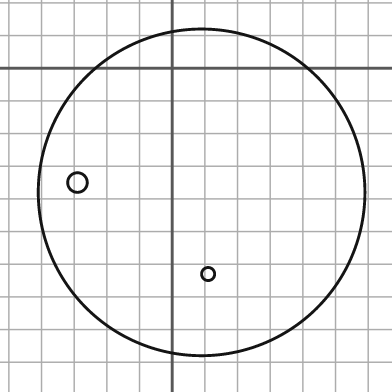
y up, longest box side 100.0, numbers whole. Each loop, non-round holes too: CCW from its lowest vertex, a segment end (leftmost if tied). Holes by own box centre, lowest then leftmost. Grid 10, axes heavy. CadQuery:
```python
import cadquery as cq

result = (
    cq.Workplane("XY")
    .moveTo(9.0, -38.0)
    .circle(50.0)
    .moveTo(11.0, -63.0)
    .circle(2.0)
    .moveTo(-29.0, -35.0)
    .circle(3.0)
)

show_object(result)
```